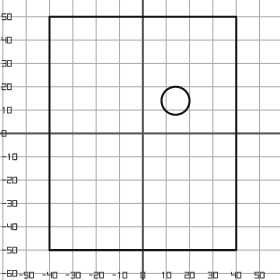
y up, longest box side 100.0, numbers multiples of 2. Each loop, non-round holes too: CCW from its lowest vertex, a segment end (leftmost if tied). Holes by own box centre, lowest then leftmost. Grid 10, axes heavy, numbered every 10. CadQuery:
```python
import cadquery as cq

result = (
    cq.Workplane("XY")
    .moveTo(-40.0, -50.0)
    .lineTo(40.0, -50.0)
    .lineTo(40.0, 50.0)
    .lineTo(-40.0, 50.0)
    .close()
    .moveTo(14.0, 14.0)
    .circle(6.0)
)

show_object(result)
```